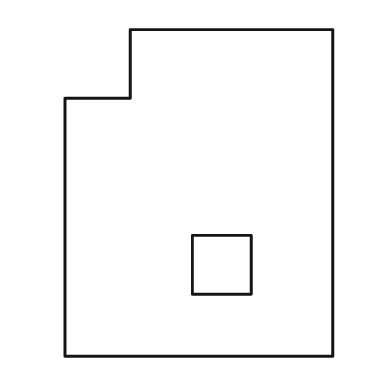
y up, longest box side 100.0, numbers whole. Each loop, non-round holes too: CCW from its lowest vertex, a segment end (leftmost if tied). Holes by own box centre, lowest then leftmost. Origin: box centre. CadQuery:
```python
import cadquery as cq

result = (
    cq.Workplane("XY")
    .moveTo(-41.0, -50.0)
    .lineTo(41.0, -50.0)
    .lineTo(41.0, 50.0)
    .lineTo(-21.0, 50.0)
    .lineTo(-21.0, 29.0)
    .lineTo(-41.0, 29.0)
    .close()
    .moveTo(-2.0, -31.0)
    .lineTo(16.0, -31.0)
    .lineTo(16.0, -13.0)
    .lineTo(-2.0, -13.0)
    .close()
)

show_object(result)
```